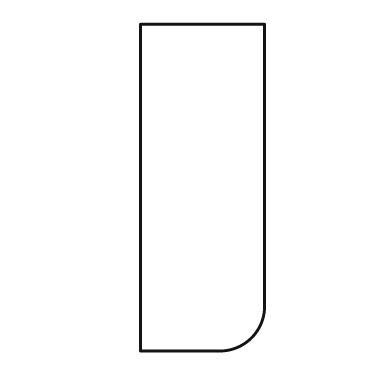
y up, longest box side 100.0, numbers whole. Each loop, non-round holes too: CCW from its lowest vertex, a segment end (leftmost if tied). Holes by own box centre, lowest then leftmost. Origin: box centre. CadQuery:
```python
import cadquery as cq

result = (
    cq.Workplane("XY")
    .moveTo(-19.0, -50.0)
    .lineTo(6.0, -50.0)
    .threePointArc((15.0, -46.0), (19.0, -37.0))
    .lineTo(19.0, 50.0)
    .lineTo(-19.0, 50.0)
    .close()
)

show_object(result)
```